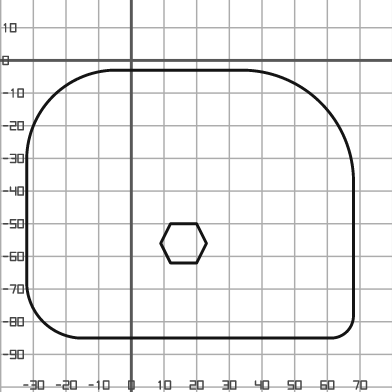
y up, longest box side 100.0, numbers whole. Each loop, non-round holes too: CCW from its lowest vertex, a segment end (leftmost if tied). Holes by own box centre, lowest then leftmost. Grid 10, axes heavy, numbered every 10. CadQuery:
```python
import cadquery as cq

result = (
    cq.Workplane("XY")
    .moveTo(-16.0, -85.0)
    .lineTo(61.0, -85.0)
    .threePointArc((66.0, -83.0), (68.0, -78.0))
    .lineTo(68.0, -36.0)
    .threePointArc((58.0, -13.0), (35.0, -3.0))
    .lineTo(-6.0, -3.0)
    .threePointArc((-24.0, -11.0), (-32.0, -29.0))
    .lineTo(-32.0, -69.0)
    .threePointArc((-27.0, -80.0), (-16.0, -85.0))
    .close()
    .moveTo(12.0, -62.0)
    .lineTo(20.0, -62.0)
    .lineTo(23.0, -56.0)
    .lineTo(20.0, -50.0)
    .lineTo(12.0, -50.0)
    .lineTo(9.0, -56.0)
    .close()
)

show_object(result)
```